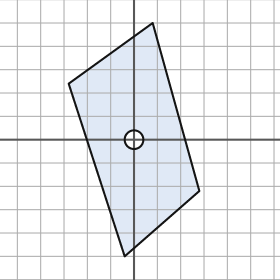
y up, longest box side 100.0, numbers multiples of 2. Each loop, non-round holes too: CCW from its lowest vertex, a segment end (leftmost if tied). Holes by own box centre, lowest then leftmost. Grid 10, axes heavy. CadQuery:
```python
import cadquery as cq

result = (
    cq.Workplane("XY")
    .moveTo(-4.0, -50.0)
    .lineTo(28.0, -22.0)
    .lineTo(8.0, 50.0)
    .lineTo(-28.0, 24.0)
    .close()
    .moveTo(0.0, 0.0)
    .circle(4.0)
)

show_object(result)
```